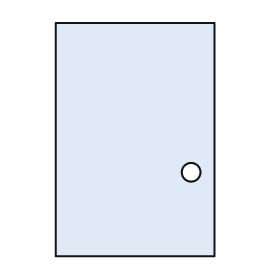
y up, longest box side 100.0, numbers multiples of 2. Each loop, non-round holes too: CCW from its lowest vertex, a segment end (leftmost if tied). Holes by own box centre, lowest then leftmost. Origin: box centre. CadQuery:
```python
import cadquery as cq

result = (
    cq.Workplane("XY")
    .moveTo(-34.0, -50.0)
    .lineTo(34.0, -50.0)
    .lineTo(34.0, 50.0)
    .lineTo(-34.0, 50.0)
    .close()
    .moveTo(24.0, -14.0)
    .circle(4.0)
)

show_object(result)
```